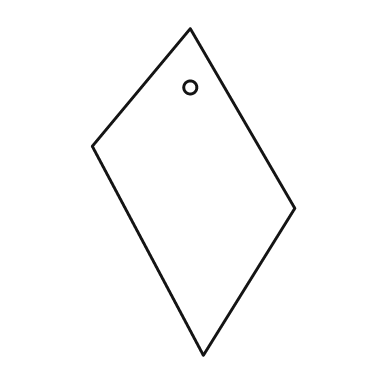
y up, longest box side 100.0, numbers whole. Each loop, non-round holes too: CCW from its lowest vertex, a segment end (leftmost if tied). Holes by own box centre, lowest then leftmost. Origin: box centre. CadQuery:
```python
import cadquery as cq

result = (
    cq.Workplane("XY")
    .moveTo(3.0, -50.0)
    .lineTo(31.0, -5.0)
    .lineTo(-1.0, 50.0)
    .lineTo(-31.0, 14.0)
    .close()
    .moveTo(-1.0, 32.0)
    .circle(2.0)
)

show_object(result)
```